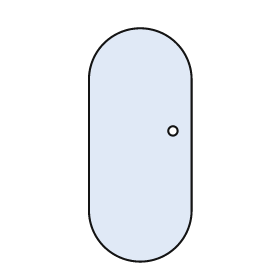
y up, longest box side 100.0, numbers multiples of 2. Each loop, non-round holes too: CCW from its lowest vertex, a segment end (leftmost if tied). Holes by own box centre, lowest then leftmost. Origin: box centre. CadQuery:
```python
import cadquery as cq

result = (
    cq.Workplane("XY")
    .moveTo(-22.0, -28.0)
    .threePointArc((0.0, -50.0), (22.0, -28.0))
    .lineTo(22.0, 28.0)
    .threePointArc((0.0, 50.0), (-22.0, 28.0))
    .close()
    .moveTo(14.0, 6.0)
    .circle(2.0)
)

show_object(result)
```